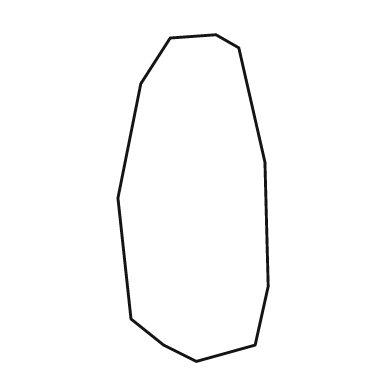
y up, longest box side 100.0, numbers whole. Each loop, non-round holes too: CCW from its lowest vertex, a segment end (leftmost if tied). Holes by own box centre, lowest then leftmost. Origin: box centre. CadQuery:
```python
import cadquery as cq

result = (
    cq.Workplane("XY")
    .moveTo(1.0, -50.0)
    .lineTo(19.0, -45.0)
    .lineTo(23.0, -27.0)
    .lineTo(22.0, 11.0)
    .lineTo(14.0, 46.0)
    .lineTo(7.0, 50.0)
    .lineTo(-7.0, 49.0)
    .lineTo(-16.0, 35.0)
    .lineTo(-23.0, 0.0)
    .lineTo(-19.0, -37.0)
    .lineTo(-9.0, -45.0)
    .close()
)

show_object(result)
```